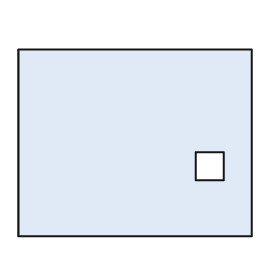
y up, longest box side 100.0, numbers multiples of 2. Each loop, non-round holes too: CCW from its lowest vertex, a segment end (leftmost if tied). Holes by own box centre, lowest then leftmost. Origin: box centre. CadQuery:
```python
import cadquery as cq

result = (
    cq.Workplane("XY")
    .moveTo(-50.0, -40.0)
    .lineTo(50.0, -40.0)
    .lineTo(50.0, 40.0)
    .lineTo(-50.0, 40.0)
    .close()
    .moveTo(26.0, -16.0)
    .lineTo(38.0, -16.0)
    .lineTo(38.0, -4.0)
    .lineTo(26.0, -4.0)
    .close()
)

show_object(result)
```